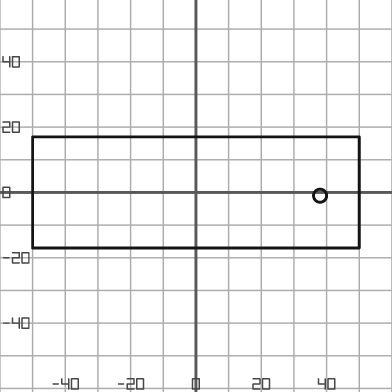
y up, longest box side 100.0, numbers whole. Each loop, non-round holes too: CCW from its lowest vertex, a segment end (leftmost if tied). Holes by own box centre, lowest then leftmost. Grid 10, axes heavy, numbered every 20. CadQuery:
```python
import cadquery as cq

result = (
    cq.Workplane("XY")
    .moveTo(-50.0, -17.0)
    .lineTo(50.0, -17.0)
    .lineTo(50.0, 17.0)
    .lineTo(-50.0, 17.0)
    .close()
    .moveTo(38.0, -1.0)
    .circle(2.0)
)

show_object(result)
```